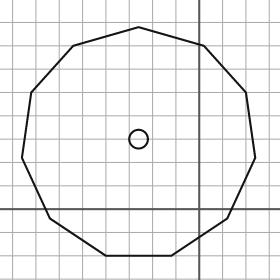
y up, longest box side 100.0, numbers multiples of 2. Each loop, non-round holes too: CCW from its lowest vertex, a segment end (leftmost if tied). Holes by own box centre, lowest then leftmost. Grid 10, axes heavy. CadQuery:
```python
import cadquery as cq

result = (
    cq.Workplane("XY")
    .moveTo(-40.0, -20.0)
    .lineTo(-12.0, -20.0)
    .lineTo(12.0, -4.0)
    .lineTo(24.0, 22.0)
    .lineTo(20.0, 50.0)
    .lineTo(2.0, 70.0)
    .lineTo(-26.0, 78.0)
    .lineTo(-54.0, 70.0)
    .lineTo(-72.0, 50.0)
    .lineTo(-76.0, 22.0)
    .lineTo(-64.0, -4.0)
    .close()
    .moveTo(-26.0, 30.0)
    .circle(4.0)
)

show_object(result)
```